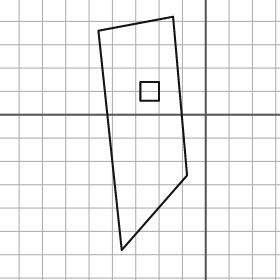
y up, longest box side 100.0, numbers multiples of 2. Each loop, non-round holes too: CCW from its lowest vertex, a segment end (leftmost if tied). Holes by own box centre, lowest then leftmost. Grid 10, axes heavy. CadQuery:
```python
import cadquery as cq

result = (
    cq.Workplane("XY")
    .moveTo(-36.0, -58.0)
    .lineTo(-8.0, -26.0)
    .lineTo(-14.0, 42.0)
    .lineTo(-46.0, 36.0)
    .close()
    .moveTo(-28.0, 6.0)
    .lineTo(-20.0, 6.0)
    .lineTo(-20.0, 14.0)
    .lineTo(-28.0, 14.0)
    .close()
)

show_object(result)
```